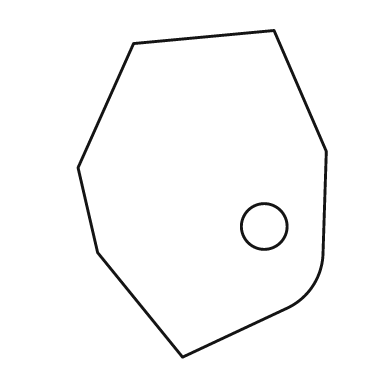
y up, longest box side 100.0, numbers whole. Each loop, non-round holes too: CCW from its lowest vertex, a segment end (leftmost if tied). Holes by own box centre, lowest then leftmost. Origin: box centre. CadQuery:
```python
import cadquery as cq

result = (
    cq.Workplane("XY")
    .moveTo(-6.0, -50.0)
    .lineTo(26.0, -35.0)
    .threePointArc((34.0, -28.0), (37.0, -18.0))
    .lineTo(38.0, 13.0)
    .lineTo(22.0, 50.0)
    .lineTo(-21.0, 46.0)
    .lineTo(-38.0, 8.0)
    .lineTo(-32.0, -18.0)
    .close()
    .moveTo(19.0, -10.0)
    .circle(7.0)
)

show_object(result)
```